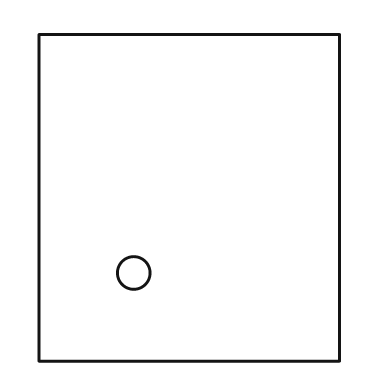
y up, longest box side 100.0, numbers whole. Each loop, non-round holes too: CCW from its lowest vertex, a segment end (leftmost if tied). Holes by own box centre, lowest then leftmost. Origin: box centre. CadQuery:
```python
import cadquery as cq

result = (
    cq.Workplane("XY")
    .moveTo(-46.0, -50.0)
    .lineTo(46.0, -50.0)
    .lineTo(46.0, 50.0)
    .lineTo(-46.0, 50.0)
    .close()
    .moveTo(-17.0, -23.0)
    .circle(5.0)
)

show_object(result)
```